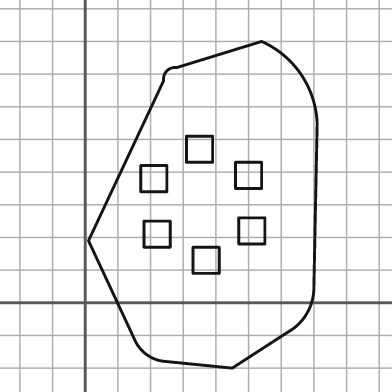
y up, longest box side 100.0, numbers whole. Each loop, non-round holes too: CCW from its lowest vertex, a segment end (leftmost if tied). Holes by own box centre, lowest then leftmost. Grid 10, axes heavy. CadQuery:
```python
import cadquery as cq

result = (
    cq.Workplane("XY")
    .moveTo(45.0, -20.0)
    .lineTo(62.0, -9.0)
    .threePointArc((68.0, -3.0), (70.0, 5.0))
    .lineTo(71.0, 55.0)
    .threePointArc((66.0, 70.0), (54.0, 80.0))
    .lineTo(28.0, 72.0)
    .threePointArc((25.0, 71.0), (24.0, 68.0))
    .lineTo(1.0, 19.0)
    .lineTo(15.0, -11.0)
    .threePointArc((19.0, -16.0), (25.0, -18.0))
    .close()
    .moveTo(33.0, 9.0)
    .lineTo(41.0, 9.0)
    .lineTo(41.0, 17.0)
    .lineTo(33.0, 17.0)
    .close()
    .moveTo(18.0, 17.0)
    .lineTo(26.0, 17.0)
    .lineTo(26.0, 25.0)
    .lineTo(18.0, 25.0)
    .close()
    .moveTo(47.0, 18.0)
    .lineTo(55.0, 18.0)
    .lineTo(55.0, 26.0)
    .lineTo(47.0, 26.0)
    .close()
    .moveTo(17.0, 34.0)
    .lineTo(25.0, 34.0)
    .lineTo(25.0, 42.0)
    .lineTo(17.0, 42.0)
    .close()
    .moveTo(46.0, 35.0)
    .lineTo(54.0, 35.0)
    .lineTo(54.0, 43.0)
    .lineTo(46.0, 43.0)
    .close()
    .moveTo(31.0, 43.0)
    .lineTo(39.0, 43.0)
    .lineTo(39.0, 51.0)
    .lineTo(31.0, 51.0)
    .close()
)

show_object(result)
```